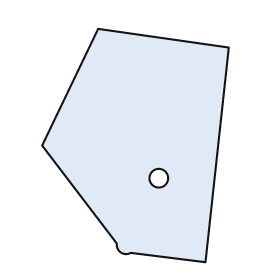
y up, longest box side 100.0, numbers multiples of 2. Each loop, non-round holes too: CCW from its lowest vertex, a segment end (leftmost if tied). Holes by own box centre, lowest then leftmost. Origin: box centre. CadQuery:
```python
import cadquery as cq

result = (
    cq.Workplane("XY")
    .moveTo(30.0, -50.0)
    .lineTo(40.0, 42.0)
    .lineTo(-16.0, 50.0)
    .lineTo(-40.0, 0.0)
    .lineTo(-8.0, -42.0)
    .threePointArc((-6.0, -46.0), (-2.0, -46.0))
    .close()
    .moveTo(10.0, -14.0)
    .circle(4.0)
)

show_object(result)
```